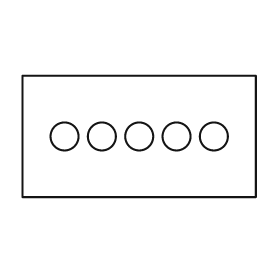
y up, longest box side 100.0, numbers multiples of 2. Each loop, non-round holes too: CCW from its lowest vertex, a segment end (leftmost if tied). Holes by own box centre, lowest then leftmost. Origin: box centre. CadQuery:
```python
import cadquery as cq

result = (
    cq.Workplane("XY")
    .moveTo(-50.0, -26.0)
    .lineTo(50.0, -26.0)
    .lineTo(50.0, 26.0)
    .lineTo(-50.0, 26.0)
    .close()
    .moveTo(-32.0, 0.0)
    .circle(6.0)
    .moveTo(-16.0, 0.0)
    .circle(6.0)
    .moveTo(0.0, 0.0)
    .circle(6.0)
    .moveTo(16.0, 0.0)
    .circle(6.0)
    .moveTo(32.0, 0.0)
    .circle(6.0)
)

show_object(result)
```